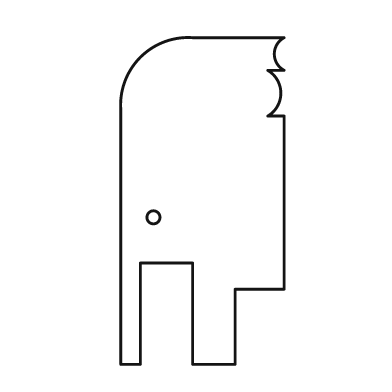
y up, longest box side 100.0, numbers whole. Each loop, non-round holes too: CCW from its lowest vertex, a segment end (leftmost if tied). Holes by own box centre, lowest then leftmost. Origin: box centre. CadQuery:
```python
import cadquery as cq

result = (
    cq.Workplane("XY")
    .moveTo(-25.0, -50.0)
    .lineTo(-19.0, -50.0)
    .lineTo(-19.0, -19.0)
    .lineTo(-3.0, -19.0)
    .lineTo(-3.0, -50.0)
    .lineTo(10.0, -50.0)
    .lineTo(10.0, -27.0)
    .lineTo(25.0, -27.0)
    .lineTo(25.0, 26.0)
    .lineTo(20.0, 26.0)
    .threePointArc((24.0, 33.0), (20.0, 40.0))
    .lineTo(25.0, 40.0)
    .threePointArc((22.0, 45.0), (25.0, 50.0))
    .lineTo(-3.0, 50.0)
    .threePointArc((-19.0, 44.0), (-25.0, 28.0))
    .close()
    .moveTo(-15.0, -5.0)
    .circle(2.0)
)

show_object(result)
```